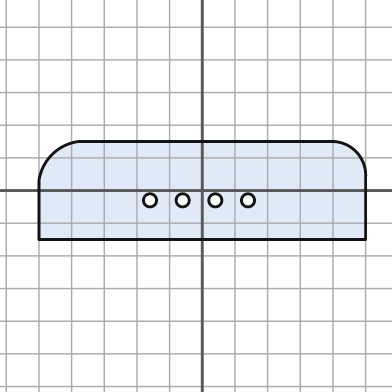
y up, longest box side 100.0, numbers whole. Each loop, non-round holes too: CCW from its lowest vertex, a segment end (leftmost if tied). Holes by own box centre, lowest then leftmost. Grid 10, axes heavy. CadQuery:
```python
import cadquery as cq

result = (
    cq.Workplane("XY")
    .moveTo(-50.0, -15.0)
    .lineTo(50.0, -15.0)
    .lineTo(50.0, 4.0)
    .threePointArc((47.0, 12.0), (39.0, 15.0))
    .lineTo(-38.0, 15.0)
    .threePointArc((-46.0, 11.0), (-50.0, 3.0))
    .close()
    .moveTo(-16.0, -3.0)
    .circle(2.0)
    .moveTo(-6.0, -3.0)
    .circle(2.0)
    .moveTo(4.0, -3.0)
    .circle(2.0)
    .moveTo(14.0, -3.0)
    .circle(2.0)
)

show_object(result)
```